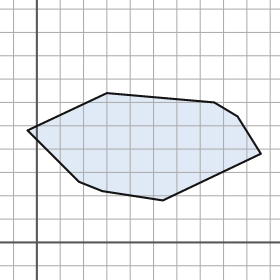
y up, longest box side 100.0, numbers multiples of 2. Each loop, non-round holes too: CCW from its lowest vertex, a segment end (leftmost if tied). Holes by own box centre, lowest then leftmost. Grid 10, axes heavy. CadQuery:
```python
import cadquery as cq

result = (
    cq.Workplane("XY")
    .moveTo(54.0, 18.0)
    .lineTo(96.0, 38.0)
    .lineTo(86.0, 54.0)
    .lineTo(76.0, 60.0)
    .lineTo(30.0, 64.0)
    .lineTo(-4.0, 48.0)
    .lineTo(18.0, 26.0)
    .lineTo(28.0, 22.0)
    .close()
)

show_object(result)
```